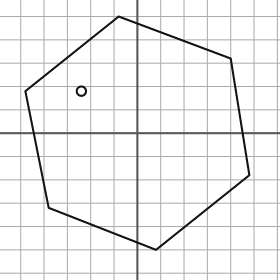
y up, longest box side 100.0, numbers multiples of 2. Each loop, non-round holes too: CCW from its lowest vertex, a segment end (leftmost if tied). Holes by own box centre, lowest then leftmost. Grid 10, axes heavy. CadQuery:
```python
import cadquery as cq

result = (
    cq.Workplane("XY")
    .moveTo(8.0, -50.0)
    .lineTo(48.0, -18.0)
    .lineTo(40.0, 32.0)
    .lineTo(-8.0, 50.0)
    .lineTo(-48.0, 18.0)
    .lineTo(-38.0, -32.0)
    .close()
    .moveTo(-24.0, 18.0)
    .circle(2.0)
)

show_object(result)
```